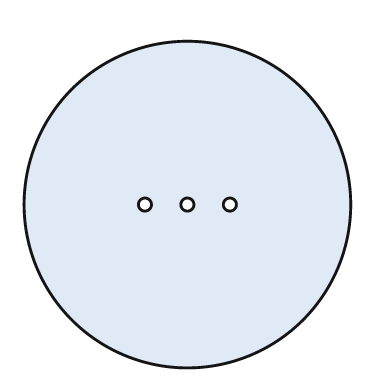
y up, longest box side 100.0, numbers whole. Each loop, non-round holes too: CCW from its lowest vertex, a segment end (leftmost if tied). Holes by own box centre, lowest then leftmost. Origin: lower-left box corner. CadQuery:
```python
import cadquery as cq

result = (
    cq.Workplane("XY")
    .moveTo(50.0, 50.0)
    .circle(50.0)
    .moveTo(37.0, 50.0)
    .circle(2.0)
    .moveTo(50.0, 50.0)
    .circle(2.0)
    .moveTo(63.0, 50.0)
    .circle(2.0)
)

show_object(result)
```